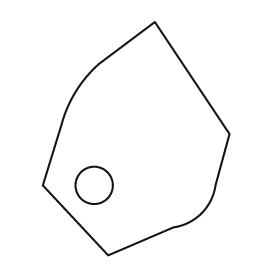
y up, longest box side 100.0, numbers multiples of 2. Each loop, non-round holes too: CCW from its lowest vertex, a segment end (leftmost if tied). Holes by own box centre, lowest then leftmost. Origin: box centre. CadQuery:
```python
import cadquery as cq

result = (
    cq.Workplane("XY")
    .moveTo(-12.0, -50.0)
    .lineTo(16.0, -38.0)
    .threePointArc((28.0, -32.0), (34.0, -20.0))
    .lineTo(40.0, 2.0)
    .lineTo(8.0, 50.0)
    .lineTo(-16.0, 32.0)
    .threePointArc((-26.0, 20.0), (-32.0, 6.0))
    .lineTo(-40.0, -20.0)
    .close()
    .moveTo(-18.0, -20.0)
    .circle(8.0)
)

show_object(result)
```